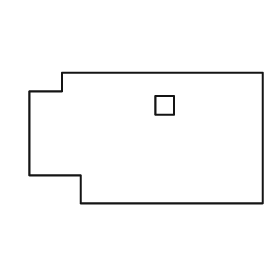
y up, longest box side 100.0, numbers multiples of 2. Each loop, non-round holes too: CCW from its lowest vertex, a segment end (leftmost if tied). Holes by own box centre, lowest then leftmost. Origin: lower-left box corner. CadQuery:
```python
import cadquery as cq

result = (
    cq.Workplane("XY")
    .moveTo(22.0, 0.0)
    .lineTo(100.0, 0.0)
    .lineTo(100.0, 56.0)
    .lineTo(14.0, 56.0)
    .lineTo(14.0, 48.0)
    .lineTo(0.0, 48.0)
    .lineTo(0.0, 12.0)
    .lineTo(22.0, 12.0)
    .close()
    .moveTo(54.0, 38.0)
    .lineTo(62.0, 38.0)
    .lineTo(62.0, 46.0)
    .lineTo(54.0, 46.0)
    .close()
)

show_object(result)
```